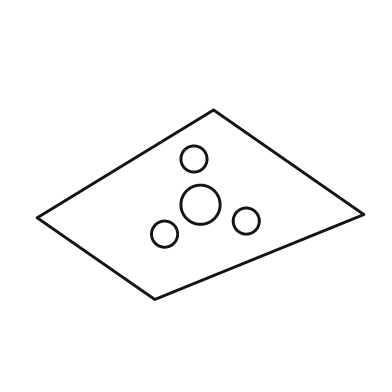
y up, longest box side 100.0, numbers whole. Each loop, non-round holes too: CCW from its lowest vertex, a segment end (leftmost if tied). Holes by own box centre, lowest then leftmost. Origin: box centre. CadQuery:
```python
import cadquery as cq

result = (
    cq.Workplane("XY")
    .moveTo(-14.0, -29.0)
    .lineTo(50.0, -3.0)
    .lineTo(4.0, 29.0)
    .lineTo(-50.0, -4.0)
    .close()
    .moveTo(-11.0, -9.0)
    .circle(4.0)
    .moveTo(14.0, -5.0)
    .circle(4.0)
    .moveTo(0.0, 0.0)
    .circle(6.0)
    .moveTo(-2.0, 14.0)
    .circle(4.0)
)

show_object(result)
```